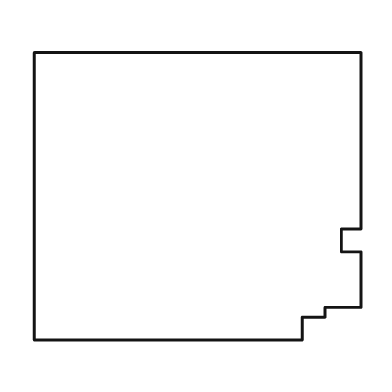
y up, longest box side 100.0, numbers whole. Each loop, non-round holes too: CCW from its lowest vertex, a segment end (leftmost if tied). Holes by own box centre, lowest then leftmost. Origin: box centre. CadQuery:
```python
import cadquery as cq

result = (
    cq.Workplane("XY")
    .moveTo(-50.0, -44.0)
    .lineTo(32.0, -44.0)
    .lineTo(32.0, -37.0)
    .lineTo(39.0, -37.0)
    .lineTo(39.0, -34.0)
    .lineTo(50.0, -34.0)
    .lineTo(50.0, -17.0)
    .lineTo(44.0, -17.0)
    .lineTo(44.0, -10.0)
    .lineTo(50.0, -10.0)
    .lineTo(50.0, 44.0)
    .lineTo(-50.0, 44.0)
    .close()
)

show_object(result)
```